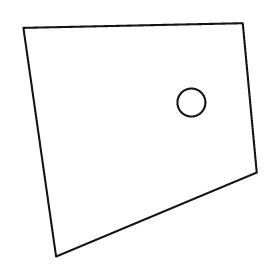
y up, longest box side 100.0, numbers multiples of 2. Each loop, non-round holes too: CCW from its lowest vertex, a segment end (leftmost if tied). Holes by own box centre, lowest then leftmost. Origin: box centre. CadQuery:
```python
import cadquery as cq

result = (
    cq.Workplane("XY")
    .moveTo(-36.0, -50.0)
    .lineTo(50.0, -14.0)
    .lineTo(44.0, 50.0)
    .lineTo(-50.0, 48.0)
    .close()
    .moveTo(22.0, 16.0)
    .circle(6.0)
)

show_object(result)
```